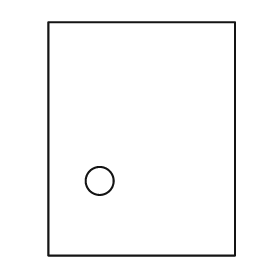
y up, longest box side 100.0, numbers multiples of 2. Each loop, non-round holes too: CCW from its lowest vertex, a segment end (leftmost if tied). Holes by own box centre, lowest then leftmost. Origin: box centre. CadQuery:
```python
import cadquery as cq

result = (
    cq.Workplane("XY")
    .moveTo(-40.0, -50.0)
    .lineTo(40.0, -50.0)
    .lineTo(40.0, 50.0)
    .lineTo(-40.0, 50.0)
    .close()
    .moveTo(-18.0, -18.0)
    .circle(6.0)
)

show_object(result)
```